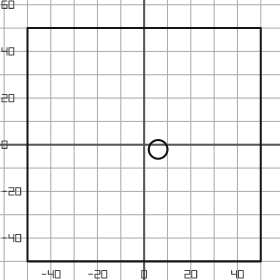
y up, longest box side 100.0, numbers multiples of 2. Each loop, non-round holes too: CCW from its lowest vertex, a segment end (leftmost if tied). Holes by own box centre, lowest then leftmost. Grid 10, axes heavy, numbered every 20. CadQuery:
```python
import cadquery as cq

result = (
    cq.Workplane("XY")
    .moveTo(-50.0, -50.0)
    .lineTo(50.0, -50.0)
    .lineTo(50.0, 50.0)
    .lineTo(-50.0, 50.0)
    .close()
    .moveTo(6.0, -2.0)
    .circle(4.0)
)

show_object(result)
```